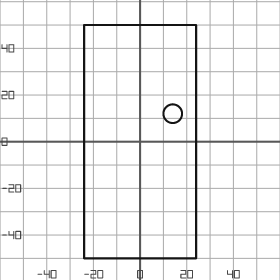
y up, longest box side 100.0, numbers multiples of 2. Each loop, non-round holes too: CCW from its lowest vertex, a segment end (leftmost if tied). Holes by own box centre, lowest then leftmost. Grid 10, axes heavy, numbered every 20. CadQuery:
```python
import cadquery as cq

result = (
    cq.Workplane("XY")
    .moveTo(-24.0, -50.0)
    .lineTo(24.0, -50.0)
    .lineTo(24.0, 50.0)
    .lineTo(-24.0, 50.0)
    .close()
    .moveTo(14.0, 12.0)
    .circle(4.0)
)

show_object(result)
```